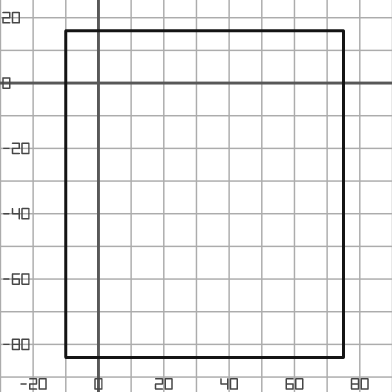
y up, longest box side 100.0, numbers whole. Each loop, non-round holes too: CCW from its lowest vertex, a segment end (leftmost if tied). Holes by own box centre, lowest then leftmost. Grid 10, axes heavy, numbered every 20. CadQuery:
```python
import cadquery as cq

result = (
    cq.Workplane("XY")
    .moveTo(-10.0, -84.0)
    .lineTo(75.0, -84.0)
    .lineTo(75.0, 16.0)
    .lineTo(-10.0, 16.0)
    .close()
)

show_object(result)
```